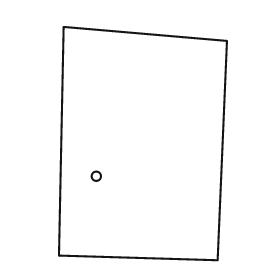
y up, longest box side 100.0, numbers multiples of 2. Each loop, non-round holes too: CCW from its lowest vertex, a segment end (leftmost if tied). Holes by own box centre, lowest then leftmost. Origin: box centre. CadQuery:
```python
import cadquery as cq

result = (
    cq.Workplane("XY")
    .moveTo(32.0, -50.0)
    .lineTo(36.0, 44.0)
    .lineTo(-34.0, 50.0)
    .lineTo(-36.0, -48.0)
    .close()
    .moveTo(-20.0, -14.0)
    .circle(2.0)
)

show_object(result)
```